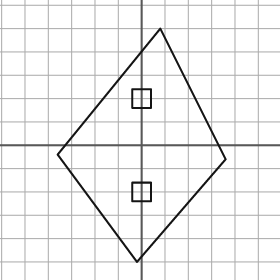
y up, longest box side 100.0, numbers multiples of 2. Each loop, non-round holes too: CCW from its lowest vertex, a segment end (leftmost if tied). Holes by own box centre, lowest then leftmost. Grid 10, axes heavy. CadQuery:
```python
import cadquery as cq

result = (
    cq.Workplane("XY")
    .moveTo(-2.0, -50.0)
    .lineTo(36.0, -6.0)
    .lineTo(8.0, 50.0)
    .lineTo(-36.0, -4.0)
    .close()
    .moveTo(-4.0, -24.0)
    .lineTo(4.0, -24.0)
    .lineTo(4.0, -16.0)
    .lineTo(-4.0, -16.0)
    .close()
    .moveTo(-4.0, 16.0)
    .lineTo(4.0, 16.0)
    .lineTo(4.0, 24.0)
    .lineTo(-4.0, 24.0)
    .close()
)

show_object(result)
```